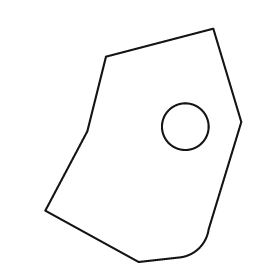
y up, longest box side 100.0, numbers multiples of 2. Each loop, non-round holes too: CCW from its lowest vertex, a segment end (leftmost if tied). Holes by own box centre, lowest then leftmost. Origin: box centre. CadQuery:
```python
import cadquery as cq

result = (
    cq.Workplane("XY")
    .moveTo(-2.0, -50.0)
    .lineTo(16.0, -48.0)
    .threePointArc((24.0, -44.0), (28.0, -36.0))
    .lineTo(42.0, 10.0)
    .lineTo(30.0, 50.0)
    .lineTo(-16.0, 38.0)
    .lineTo(-24.0, 6.0)
    .lineTo(-42.0, -28.0)
    .close()
    .moveTo(18.0, 8.0)
    .circle(10.0)
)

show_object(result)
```